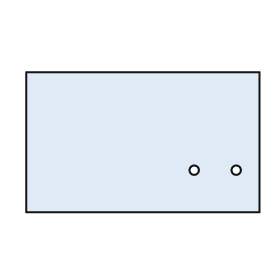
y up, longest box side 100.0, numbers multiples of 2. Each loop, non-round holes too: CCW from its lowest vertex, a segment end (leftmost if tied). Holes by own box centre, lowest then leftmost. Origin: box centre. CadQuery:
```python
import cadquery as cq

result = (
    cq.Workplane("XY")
    .moveTo(-50.0, -30.0)
    .lineTo(50.0, -30.0)
    .lineTo(50.0, 30.0)
    .lineTo(-50.0, 30.0)
    .close()
    .moveTo(22.0, -12.0)
    .circle(2.0)
    .moveTo(40.0, -12.0)
    .circle(2.0)
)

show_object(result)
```